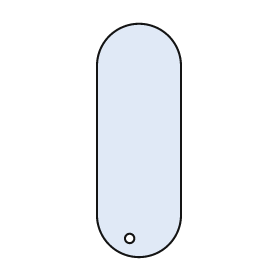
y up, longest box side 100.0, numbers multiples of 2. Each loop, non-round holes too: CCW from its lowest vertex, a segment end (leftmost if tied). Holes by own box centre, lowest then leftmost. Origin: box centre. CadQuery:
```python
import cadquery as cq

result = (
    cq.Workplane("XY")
    .moveTo(-18.0, -32.0)
    .threePointArc((0.0, -50.0), (18.0, -32.0))
    .lineTo(18.0, 32.0)
    .threePointArc((0.0, 50.0), (-18.0, 32.0))
    .close()
    .moveTo(-4.0, -42.0)
    .circle(2.0)
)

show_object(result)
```